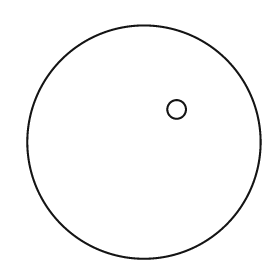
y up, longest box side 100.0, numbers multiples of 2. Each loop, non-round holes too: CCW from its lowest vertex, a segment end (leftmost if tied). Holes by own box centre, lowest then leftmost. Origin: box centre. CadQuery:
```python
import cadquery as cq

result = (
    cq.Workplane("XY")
    .moveTo(0.0, 0.0)
    .circle(50.0)
    .moveTo(14.0, 14.0)
    .circle(4.0)
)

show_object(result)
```